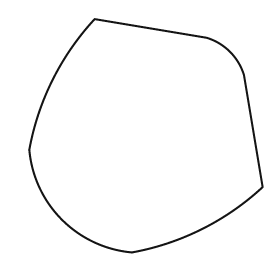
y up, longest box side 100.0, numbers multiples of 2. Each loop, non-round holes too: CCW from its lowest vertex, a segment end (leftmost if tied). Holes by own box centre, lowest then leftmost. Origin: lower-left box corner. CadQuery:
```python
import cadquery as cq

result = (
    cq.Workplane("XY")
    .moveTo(44.0, 0.0)
    .threePointArc((74.0, 10.0), (100.0, 28.0))
    .lineTo(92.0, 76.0)
    .threePointArc((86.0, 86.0), (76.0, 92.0))
    .lineTo(28.0, 100.0)
    .threePointArc((10.0, 74.0), (0.0, 44.0))
    .threePointArc((14.0, 14.0), (44.0, 0.0))
    .close()
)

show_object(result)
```